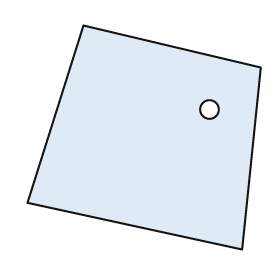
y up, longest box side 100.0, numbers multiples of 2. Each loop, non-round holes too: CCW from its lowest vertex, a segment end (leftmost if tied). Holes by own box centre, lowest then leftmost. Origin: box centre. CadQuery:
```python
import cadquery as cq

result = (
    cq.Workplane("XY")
    .moveTo(42.0, -48.0)
    .lineTo(50.0, 30.0)
    .lineTo(-26.0, 48.0)
    .lineTo(-50.0, -28.0)
    .close()
    .moveTo(28.0, 12.0)
    .circle(4.0)
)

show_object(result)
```